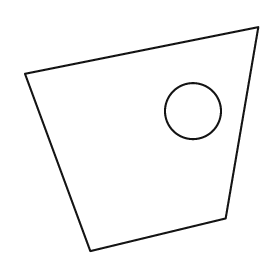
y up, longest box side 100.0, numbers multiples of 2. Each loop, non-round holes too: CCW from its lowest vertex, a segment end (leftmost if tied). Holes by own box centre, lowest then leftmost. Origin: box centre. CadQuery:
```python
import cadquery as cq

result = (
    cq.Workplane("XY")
    .moveTo(-22.0, -48.0)
    .lineTo(36.0, -34.0)
    .lineTo(50.0, 48.0)
    .lineTo(-50.0, 28.0)
    .close()
    .moveTo(22.0, 12.0)
    .circle(12.0)
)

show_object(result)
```